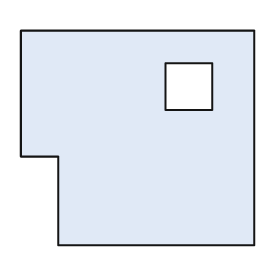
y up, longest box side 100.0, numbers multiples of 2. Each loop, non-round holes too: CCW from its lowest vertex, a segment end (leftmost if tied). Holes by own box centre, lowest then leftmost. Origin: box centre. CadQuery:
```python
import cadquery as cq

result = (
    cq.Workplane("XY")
    .moveTo(-34.0, -46.0)
    .lineTo(50.0, -46.0)
    .lineTo(50.0, 46.0)
    .lineTo(-50.0, 46.0)
    .lineTo(-50.0, -8.0)
    .lineTo(-34.0, -8.0)
    .close()
    .moveTo(12.0, 12.0)
    .lineTo(32.0, 12.0)
    .lineTo(32.0, 32.0)
    .lineTo(12.0, 32.0)
    .close()
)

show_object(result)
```